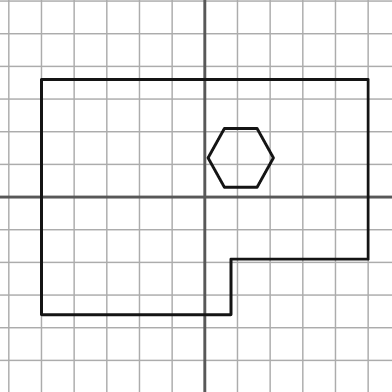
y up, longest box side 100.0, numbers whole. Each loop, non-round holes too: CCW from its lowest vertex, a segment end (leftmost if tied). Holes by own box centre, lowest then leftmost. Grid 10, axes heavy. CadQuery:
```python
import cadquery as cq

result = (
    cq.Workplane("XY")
    .moveTo(-50.0, -36.0)
    .lineTo(8.0, -36.0)
    .lineTo(8.0, -19.0)
    .lineTo(50.0, -19.0)
    .lineTo(50.0, 36.0)
    .lineTo(-50.0, 36.0)
    .close()
    .moveTo(6.0, 3.0)
    .lineTo(16.0, 3.0)
    .lineTo(21.0, 12.0)
    .lineTo(16.0, 21.0)
    .lineTo(6.0, 21.0)
    .lineTo(1.0, 12.0)
    .close()
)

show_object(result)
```